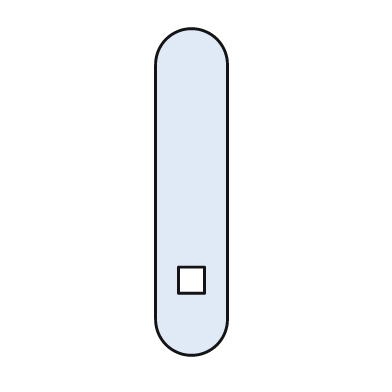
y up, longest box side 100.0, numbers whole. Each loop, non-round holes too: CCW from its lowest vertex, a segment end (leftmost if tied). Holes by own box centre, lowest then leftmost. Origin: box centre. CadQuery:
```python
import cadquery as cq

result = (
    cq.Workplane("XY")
    .moveTo(-11.0, -39.0)
    .threePointArc((0.0, -50.0), (11.0, -39.0))
    .lineTo(11.0, 39.0)
    .threePointArc((0.0, 50.0), (-11.0, 39.0))
    .close()
    .moveTo(-4.0, -31.0)
    .lineTo(4.0, -31.0)
    .lineTo(4.0, -23.0)
    .lineTo(-4.0, -23.0)
    .close()
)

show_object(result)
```